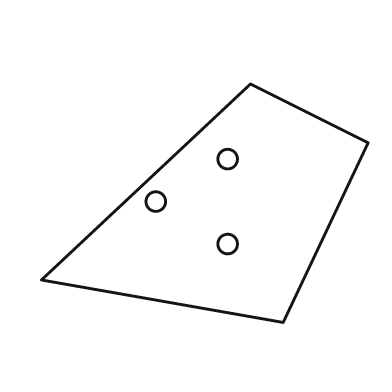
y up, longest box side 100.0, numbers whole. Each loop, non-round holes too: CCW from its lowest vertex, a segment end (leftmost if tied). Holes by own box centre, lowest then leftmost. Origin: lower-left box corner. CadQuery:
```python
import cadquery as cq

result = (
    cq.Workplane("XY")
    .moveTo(74.0, 0.0)
    .lineTo(100.0, 55.0)
    .lineTo(64.0, 73.0)
    .lineTo(0.0, 13.0)
    .close()
    .moveTo(57.0, 24.0)
    .circle(3.0)
    .moveTo(35.0, 37.0)
    .circle(3.0)
    .moveTo(57.0, 50.0)
    .circle(3.0)
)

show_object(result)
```